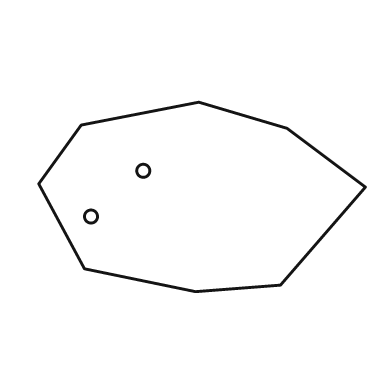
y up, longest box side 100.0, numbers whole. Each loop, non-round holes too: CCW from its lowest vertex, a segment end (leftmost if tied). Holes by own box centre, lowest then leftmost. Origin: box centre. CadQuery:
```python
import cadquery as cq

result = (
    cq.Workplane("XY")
    .moveTo(-2.0, -29.0)
    .lineTo(24.0, -27.0)
    .lineTo(50.0, 3.0)
    .lineTo(26.0, 21.0)
    .lineTo(-1.0, 29.0)
    .lineTo(-37.0, 22.0)
    .lineTo(-50.0, 4.0)
    .lineTo(-36.0, -22.0)
    .close()
    .moveTo(-34.0, -6.0)
    .circle(2.0)
    .moveTo(-18.0, 8.0)
    .circle(2.0)
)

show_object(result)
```